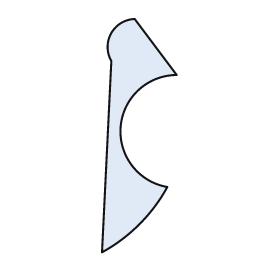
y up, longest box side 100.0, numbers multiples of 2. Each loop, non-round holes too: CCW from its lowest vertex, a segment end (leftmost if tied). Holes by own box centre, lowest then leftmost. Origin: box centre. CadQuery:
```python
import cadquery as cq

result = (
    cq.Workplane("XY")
    .moveTo(-16.0, -50.0)
    .threePointArc((0.0, -38.0), (12.0, -22.0))
    .threePointArc((-8.0, 4.0), (16.0, 26.0))
    .lineTo(-2.0, 50.0)
    .threePointArc((-12.0, 44.0), (-12.0, 32.0))
    .close()
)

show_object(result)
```